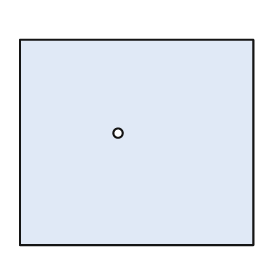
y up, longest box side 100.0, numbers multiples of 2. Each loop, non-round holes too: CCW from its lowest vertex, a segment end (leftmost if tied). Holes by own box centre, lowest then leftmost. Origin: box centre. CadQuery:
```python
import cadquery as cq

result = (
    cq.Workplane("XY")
    .moveTo(-50.0, -44.0)
    .lineTo(50.0, -44.0)
    .lineTo(50.0, 44.0)
    .lineTo(-50.0, 44.0)
    .close()
    .moveTo(-8.0, 4.0)
    .circle(2.0)
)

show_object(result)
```